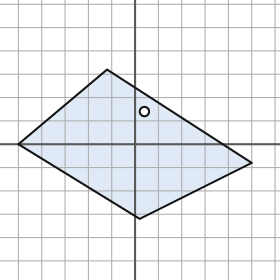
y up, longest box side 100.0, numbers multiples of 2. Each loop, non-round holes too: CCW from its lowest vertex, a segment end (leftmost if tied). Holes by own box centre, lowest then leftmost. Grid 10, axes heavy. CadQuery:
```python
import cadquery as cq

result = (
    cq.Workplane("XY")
    .moveTo(2.0, -32.0)
    .lineTo(50.0, -8.0)
    .lineTo(-12.0, 32.0)
    .lineTo(-50.0, 0.0)
    .close()
    .moveTo(4.0, 14.0)
    .circle(2.0)
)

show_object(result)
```